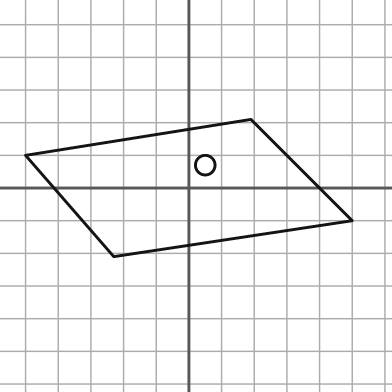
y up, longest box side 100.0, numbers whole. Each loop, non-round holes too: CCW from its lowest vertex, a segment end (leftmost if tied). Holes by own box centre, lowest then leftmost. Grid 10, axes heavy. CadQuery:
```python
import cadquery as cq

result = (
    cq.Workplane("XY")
    .moveTo(-23.0, -21.0)
    .lineTo(50.0, -10.0)
    .lineTo(19.0, 21.0)
    .lineTo(-50.0, 10.0)
    .close()
    .moveTo(5.0, 7.0)
    .circle(3.0)
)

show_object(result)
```